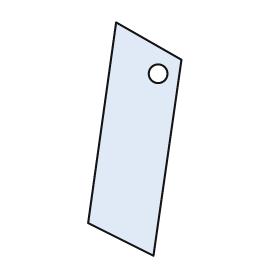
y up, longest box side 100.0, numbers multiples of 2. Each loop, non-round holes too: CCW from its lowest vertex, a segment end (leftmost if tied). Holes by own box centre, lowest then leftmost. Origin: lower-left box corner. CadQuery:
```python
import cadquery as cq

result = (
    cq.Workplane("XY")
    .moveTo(28.0, 0.0)
    .lineTo(40.0, 84.0)
    .lineTo(12.0, 100.0)
    .lineTo(0.0, 14.0)
    .close()
    .moveTo(30.0, 78.0)
    .circle(4.0)
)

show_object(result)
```